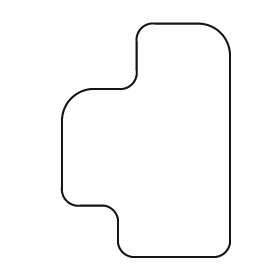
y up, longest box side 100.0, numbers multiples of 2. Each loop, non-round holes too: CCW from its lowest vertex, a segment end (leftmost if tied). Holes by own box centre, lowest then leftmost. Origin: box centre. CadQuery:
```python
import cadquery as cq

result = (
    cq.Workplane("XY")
    .moveTo(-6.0, -50.0)
    .lineTo(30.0, -50.0)
    .threePointArc((34.0, -48.0), (36.0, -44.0))
    .lineTo(36.0, 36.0)
    .threePointArc((32.0, 46.0), (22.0, 50.0))
    .lineTo(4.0, 50.0)
    .threePointArc((-2.0, 48.0), (-4.0, 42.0))
    .lineTo(-4.0, 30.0)
    .threePointArc((-6.0, 24.0), (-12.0, 22.0))
    .lineTo(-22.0, 22.0)
    .threePointArc((-32.0, 18.0), (-36.0, 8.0))
    .lineTo(-36.0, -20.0)
    .threePointArc((-34.0, -26.0), (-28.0, -28.0))
    .lineTo(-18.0, -28.0)
    .threePointArc((-14.0, -30.0), (-12.0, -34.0))
    .lineTo(-12.0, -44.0)
    .threePointArc((-10.0, -48.0), (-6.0, -50.0))
    .close()
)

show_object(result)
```